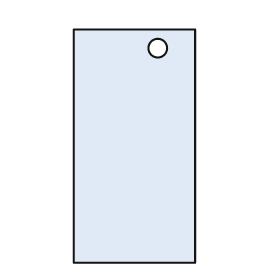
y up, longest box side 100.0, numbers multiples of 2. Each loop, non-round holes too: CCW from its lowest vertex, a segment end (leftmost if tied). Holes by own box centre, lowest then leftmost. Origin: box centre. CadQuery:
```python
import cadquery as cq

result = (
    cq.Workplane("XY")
    .moveTo(-26.0, -50.0)
    .lineTo(26.0, -50.0)
    .lineTo(26.0, 50.0)
    .lineTo(-26.0, 50.0)
    .close()
    .moveTo(10.0, 42.0)
    .circle(4.0)
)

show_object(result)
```